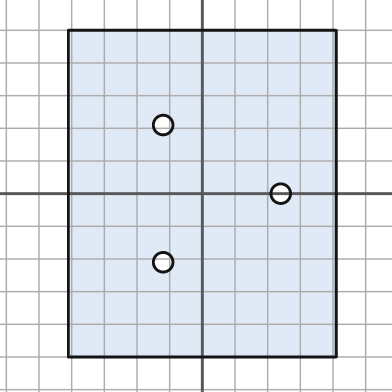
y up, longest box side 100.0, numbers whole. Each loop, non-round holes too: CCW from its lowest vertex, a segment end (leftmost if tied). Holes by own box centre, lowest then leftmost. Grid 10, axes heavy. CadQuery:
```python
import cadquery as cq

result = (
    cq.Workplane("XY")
    .moveTo(-41.0, -50.0)
    .lineTo(41.0, -50.0)
    .lineTo(41.0, 50.0)
    .lineTo(-41.0, 50.0)
    .close()
    .moveTo(-12.0, -21.0)
    .circle(3.0)
    .moveTo(24.0, 0.0)
    .circle(3.0)
    .moveTo(-12.0, 21.0)
    .circle(3.0)
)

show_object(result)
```